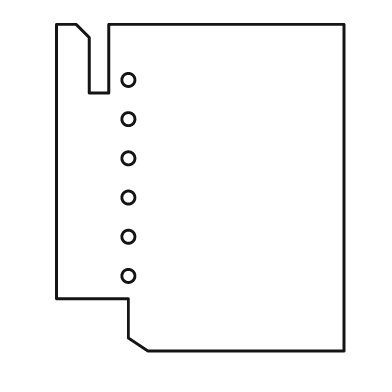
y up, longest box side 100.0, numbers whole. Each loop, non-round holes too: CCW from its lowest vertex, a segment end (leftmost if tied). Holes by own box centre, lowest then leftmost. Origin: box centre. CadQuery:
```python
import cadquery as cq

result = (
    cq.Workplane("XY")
    .moveTo(-16.0, -50.0)
    .lineTo(44.0, -50.0)
    .lineTo(44.0, 50.0)
    .lineTo(-28.0, 50.0)
    .lineTo(-28.0, 29.0)
    .lineTo(-34.0, 29.0)
    .lineTo(-34.0, 46.0)
    .lineTo(-38.0, 50.0)
    .lineTo(-44.0, 50.0)
    .lineTo(-44.0, -34.0)
    .lineTo(-22.0, -34.0)
    .lineTo(-22.0, -46.0)
    .close()
    .moveTo(-22.0, -27.0)
    .circle(2.0)
    .moveTo(-22.0, -15.0)
    .circle(2.0)
    .moveTo(-22.0, -3.0)
    .circle(2.0)
    .moveTo(-22.0, 9.0)
    .circle(2.0)
    .moveTo(-22.0, 21.0)
    .circle(2.0)
    .moveTo(-22.0, 33.0)
    .circle(2.0)
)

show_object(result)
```